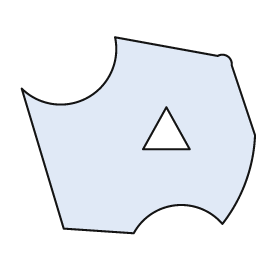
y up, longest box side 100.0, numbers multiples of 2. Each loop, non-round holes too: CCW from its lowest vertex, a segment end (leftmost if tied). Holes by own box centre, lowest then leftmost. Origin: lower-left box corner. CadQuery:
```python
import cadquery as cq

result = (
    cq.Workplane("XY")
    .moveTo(48.0, 0.0)
    .threePointArc((66.0, 12.0), (86.0, 4.0))
    .threePointArc((96.0, 22.0), (100.0, 42.0))
    .lineTo(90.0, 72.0)
    .threePointArc((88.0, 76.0), (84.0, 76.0))
    .lineTo(40.0, 84.0)
    .threePointArc((28.0, 58.0), (0.0, 62.0))
    .lineTo(18.0, 2.0)
    .close()
    .moveTo(52.0, 36.0)
    .lineTo(72.0, 36.0)
    .lineTo(62.0, 54.0)
    .close()
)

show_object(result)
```